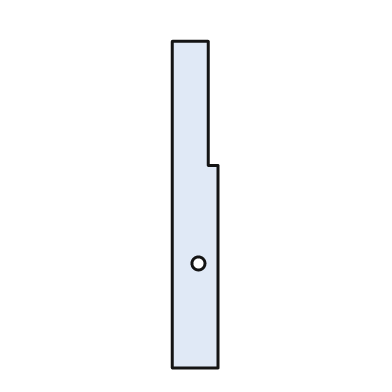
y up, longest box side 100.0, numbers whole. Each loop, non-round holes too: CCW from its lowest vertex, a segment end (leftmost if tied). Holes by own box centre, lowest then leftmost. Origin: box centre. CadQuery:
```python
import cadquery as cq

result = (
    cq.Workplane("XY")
    .moveTo(-7.0, -50.0)
    .lineTo(7.0, -50.0)
    .lineTo(7.0, 12.0)
    .lineTo(4.0, 12.0)
    .lineTo(4.0, 50.0)
    .lineTo(-7.0, 50.0)
    .close()
    .moveTo(1.0, -18.0)
    .circle(2.0)
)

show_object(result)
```